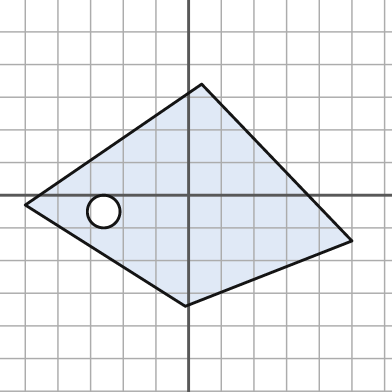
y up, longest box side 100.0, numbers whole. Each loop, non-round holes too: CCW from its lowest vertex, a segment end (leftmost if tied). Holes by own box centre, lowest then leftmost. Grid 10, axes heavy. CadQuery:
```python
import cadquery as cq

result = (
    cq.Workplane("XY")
    .moveTo(-1.0, -34.0)
    .lineTo(50.0, -14.0)
    .lineTo(4.0, 34.0)
    .lineTo(-50.0, -3.0)
    .close()
    .moveTo(-26.0, -5.0)
    .circle(5.0)
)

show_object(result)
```